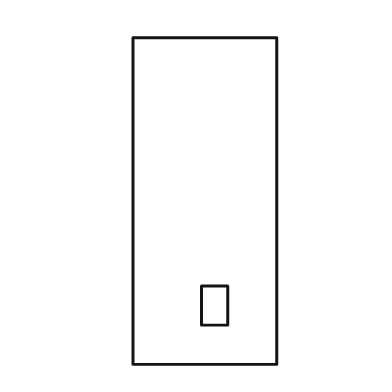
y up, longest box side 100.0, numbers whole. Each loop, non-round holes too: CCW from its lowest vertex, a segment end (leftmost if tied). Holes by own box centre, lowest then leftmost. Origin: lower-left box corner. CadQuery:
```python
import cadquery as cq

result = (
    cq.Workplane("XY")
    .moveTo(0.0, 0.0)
    .lineTo(44.0, 0.0)
    .lineTo(44.0, 100.0)
    .lineTo(0.0, 100.0)
    .close()
    .moveTo(21.0, 12.0)
    .lineTo(29.0, 12.0)
    .lineTo(29.0, 24.0)
    .lineTo(21.0, 24.0)
    .close()
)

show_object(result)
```